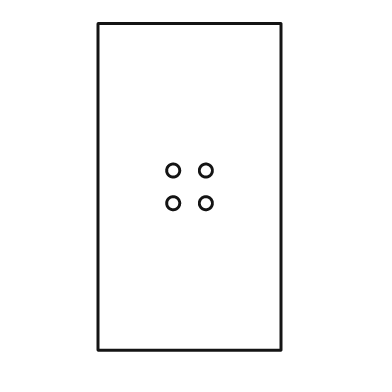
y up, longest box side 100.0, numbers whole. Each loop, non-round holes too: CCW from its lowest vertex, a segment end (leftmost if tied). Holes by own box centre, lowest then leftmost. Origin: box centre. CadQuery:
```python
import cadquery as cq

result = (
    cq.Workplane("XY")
    .moveTo(-28.0, -50.0)
    .lineTo(28.0, -50.0)
    .lineTo(28.0, 50.0)
    .lineTo(-28.0, 50.0)
    .close()
    .moveTo(-5.0, -5.0)
    .circle(2.0)
    .moveTo(5.0, -5.0)
    .circle(2.0)
    .moveTo(-5.0, 5.0)
    .circle(2.0)
    .moveTo(5.0, 5.0)
    .circle(2.0)
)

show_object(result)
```